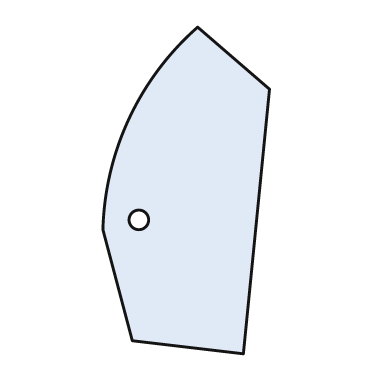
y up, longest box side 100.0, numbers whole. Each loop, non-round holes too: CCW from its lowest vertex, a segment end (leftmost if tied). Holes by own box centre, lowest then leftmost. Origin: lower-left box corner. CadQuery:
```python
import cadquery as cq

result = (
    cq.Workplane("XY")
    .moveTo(43.0, 0.0)
    .lineTo(51.0, 81.0)
    .lineTo(29.0, 100.0)
    .threePointArc((8.0, 72.0), (0.0, 38.0))
    .lineTo(9.0, 4.0)
    .close()
    .moveTo(11.0, 41.0)
    .circle(3.0)
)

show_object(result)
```